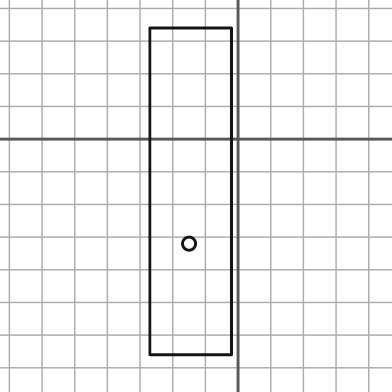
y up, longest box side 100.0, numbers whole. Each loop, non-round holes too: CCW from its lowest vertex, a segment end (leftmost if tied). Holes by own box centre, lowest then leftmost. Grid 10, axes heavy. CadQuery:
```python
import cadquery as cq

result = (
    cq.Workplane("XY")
    .moveTo(-27.0, -66.0)
    .lineTo(-2.0, -66.0)
    .lineTo(-2.0, 34.0)
    .lineTo(-27.0, 34.0)
    .close()
    .moveTo(-15.0, -32.0)
    .circle(2.0)
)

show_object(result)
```